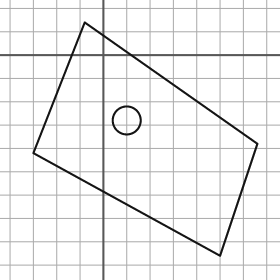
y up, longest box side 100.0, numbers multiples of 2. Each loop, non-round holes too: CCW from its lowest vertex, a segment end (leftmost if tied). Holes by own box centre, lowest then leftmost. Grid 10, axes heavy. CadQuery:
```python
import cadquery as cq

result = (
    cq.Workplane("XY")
    .moveTo(50.0, -86.0)
    .lineTo(66.0, -38.0)
    .lineTo(-8.0, 14.0)
    .lineTo(-30.0, -42.0)
    .close()
    .moveTo(10.0, -28.0)
    .circle(6.0)
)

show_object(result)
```